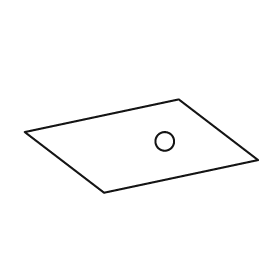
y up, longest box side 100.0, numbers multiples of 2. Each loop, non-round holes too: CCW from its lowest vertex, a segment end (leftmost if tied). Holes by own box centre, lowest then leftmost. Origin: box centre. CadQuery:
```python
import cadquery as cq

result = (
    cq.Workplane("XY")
    .moveTo(-16.0, -20.0)
    .lineTo(50.0, -6.0)
    .lineTo(16.0, 20.0)
    .lineTo(-50.0, 6.0)
    .close()
    .moveTo(10.0, 2.0)
    .circle(4.0)
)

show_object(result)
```